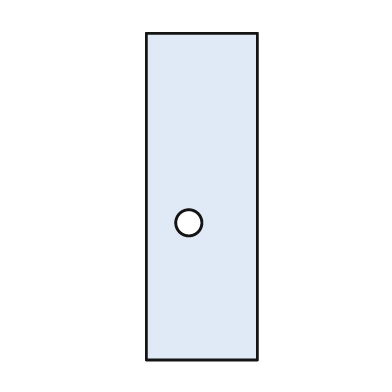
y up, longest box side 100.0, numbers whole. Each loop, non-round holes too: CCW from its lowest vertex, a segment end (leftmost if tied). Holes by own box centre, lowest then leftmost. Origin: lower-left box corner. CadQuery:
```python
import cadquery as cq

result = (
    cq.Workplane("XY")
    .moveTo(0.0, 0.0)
    .lineTo(34.0, 0.0)
    .lineTo(34.0, 100.0)
    .lineTo(0.0, 100.0)
    .close()
    .moveTo(13.0, 42.0)
    .circle(4.0)
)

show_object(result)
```